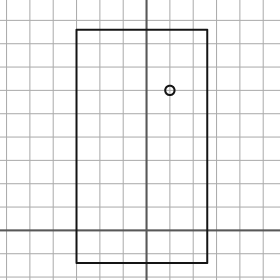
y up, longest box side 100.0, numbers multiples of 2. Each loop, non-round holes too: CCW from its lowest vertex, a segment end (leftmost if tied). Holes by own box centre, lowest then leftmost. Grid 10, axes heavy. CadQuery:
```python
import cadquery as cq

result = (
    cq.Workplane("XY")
    .moveTo(-30.0, -14.0)
    .lineTo(26.0, -14.0)
    .lineTo(26.0, 86.0)
    .lineTo(-30.0, 86.0)
    .close()
    .moveTo(10.0, 60.0)
    .circle(2.0)
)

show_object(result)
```